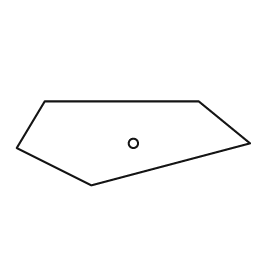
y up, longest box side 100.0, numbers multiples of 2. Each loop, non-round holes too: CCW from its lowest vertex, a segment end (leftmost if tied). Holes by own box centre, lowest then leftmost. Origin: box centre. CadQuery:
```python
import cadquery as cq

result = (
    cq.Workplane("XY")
    .moveTo(-18.0, -18.0)
    .lineTo(50.0, 0.0)
    .lineTo(28.0, 18.0)
    .lineTo(-38.0, 18.0)
    .lineTo(-50.0, -2.0)
    .close()
    .moveTo(0.0, 0.0)
    .circle(2.0)
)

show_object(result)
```